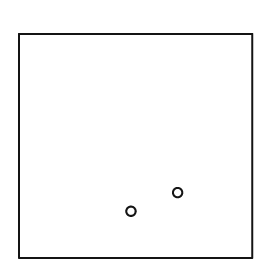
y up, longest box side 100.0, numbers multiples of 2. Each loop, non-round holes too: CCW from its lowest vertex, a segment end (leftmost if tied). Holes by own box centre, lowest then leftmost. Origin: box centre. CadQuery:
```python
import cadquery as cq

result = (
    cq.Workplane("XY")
    .moveTo(-50.0, -48.0)
    .lineTo(50.0, -48.0)
    .lineTo(50.0, 48.0)
    .lineTo(-50.0, 48.0)
    .close()
    .moveTo(-2.0, -28.0)
    .circle(2.0)
    .moveTo(18.0, -20.0)
    .circle(2.0)
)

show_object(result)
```